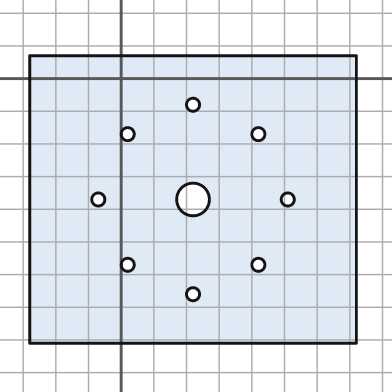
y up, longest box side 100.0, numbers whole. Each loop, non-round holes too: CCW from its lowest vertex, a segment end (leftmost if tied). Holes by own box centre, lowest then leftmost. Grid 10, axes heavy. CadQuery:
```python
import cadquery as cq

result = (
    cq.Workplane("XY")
    .moveTo(-28.0, -81.0)
    .lineTo(72.0, -81.0)
    .lineTo(72.0, 7.0)
    .lineTo(-28.0, 7.0)
    .close()
    .moveTo(22.0, -66.0)
    .circle(2.0)
    .moveTo(2.0, -57.0)
    .circle(2.0)
    .moveTo(42.0, -57.0)
    .circle(2.0)
    .moveTo(-7.0, -37.0)
    .circle(2.0)
    .moveTo(22.0, -37.0)
    .circle(5.0)
    .moveTo(51.0, -37.0)
    .circle(2.0)
    .moveTo(2.0, -17.0)
    .circle(2.0)
    .moveTo(42.0, -17.0)
    .circle(2.0)
    .moveTo(22.0, -8.0)
    .circle(2.0)
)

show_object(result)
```